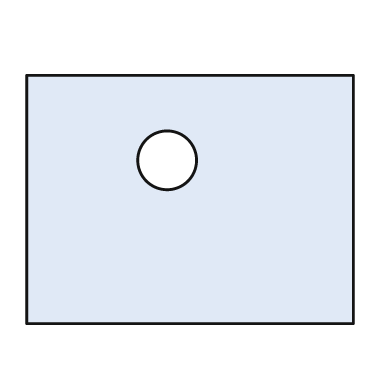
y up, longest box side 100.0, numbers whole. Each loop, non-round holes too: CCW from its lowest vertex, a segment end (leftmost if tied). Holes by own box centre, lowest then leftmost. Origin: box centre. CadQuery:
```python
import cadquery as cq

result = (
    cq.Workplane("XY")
    .moveTo(-50.0, -38.0)
    .lineTo(50.0, -38.0)
    .lineTo(50.0, 38.0)
    .lineTo(-50.0, 38.0)
    .close()
    .moveTo(-7.0, 12.0)
    .circle(9.0)
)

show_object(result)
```